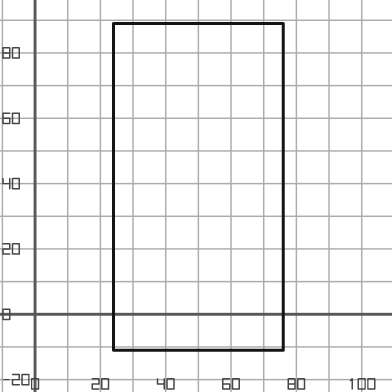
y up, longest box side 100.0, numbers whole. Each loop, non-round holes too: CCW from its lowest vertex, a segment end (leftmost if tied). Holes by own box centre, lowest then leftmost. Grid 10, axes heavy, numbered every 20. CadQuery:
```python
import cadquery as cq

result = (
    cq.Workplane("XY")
    .moveTo(24.0, -11.0)
    .lineTo(76.0, -11.0)
    .lineTo(76.0, 89.0)
    .lineTo(24.0, 89.0)
    .close()
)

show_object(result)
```